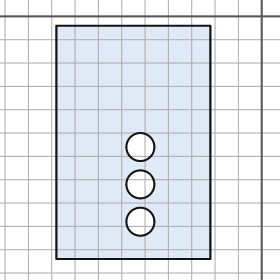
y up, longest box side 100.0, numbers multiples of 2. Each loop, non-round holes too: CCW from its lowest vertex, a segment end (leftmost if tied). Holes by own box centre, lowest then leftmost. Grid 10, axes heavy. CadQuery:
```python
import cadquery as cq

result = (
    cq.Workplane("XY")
    .moveTo(-88.0, -104.0)
    .lineTo(-22.0, -104.0)
    .lineTo(-22.0, -4.0)
    .lineTo(-88.0, -4.0)
    .close()
    .moveTo(-52.0, -88.0)
    .circle(6.0)
    .moveTo(-52.0, -72.0)
    .circle(6.0)
    .moveTo(-52.0, -56.0)
    .circle(6.0)
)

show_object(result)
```